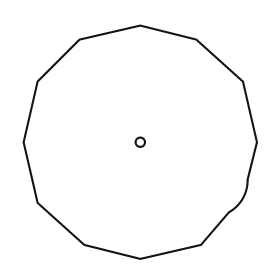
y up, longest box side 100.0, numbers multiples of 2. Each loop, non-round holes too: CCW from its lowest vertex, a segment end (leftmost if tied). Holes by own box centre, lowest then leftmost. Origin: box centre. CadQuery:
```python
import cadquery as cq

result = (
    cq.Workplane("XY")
    .moveTo(0.0, -50.0)
    .lineTo(26.0, -44.0)
    .lineTo(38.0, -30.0)
    .threePointArc((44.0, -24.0), (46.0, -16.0))
    .lineTo(50.0, 0.0)
    .lineTo(44.0, 26.0)
    .lineTo(24.0, 44.0)
    .lineTo(0.0, 50.0)
    .lineTo(-26.0, 44.0)
    .lineTo(-44.0, 26.0)
    .lineTo(-50.0, 0.0)
    .lineTo(-44.0, -26.0)
    .lineTo(-24.0, -44.0)
    .close()
    .moveTo(0.0, 0.0)
    .circle(2.0)
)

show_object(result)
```